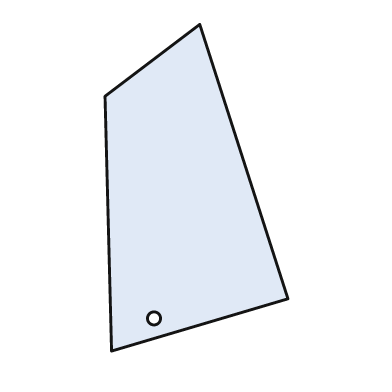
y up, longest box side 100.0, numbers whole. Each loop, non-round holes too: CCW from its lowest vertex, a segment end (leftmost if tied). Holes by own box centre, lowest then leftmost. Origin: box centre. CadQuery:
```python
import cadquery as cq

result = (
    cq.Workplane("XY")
    .moveTo(-26.0, -50.0)
    .lineTo(28.0, -34.0)
    .lineTo(1.0, 50.0)
    .lineTo(-28.0, 28.0)
    .close()
    .moveTo(-13.0, -40.0)
    .circle(2.0)
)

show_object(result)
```